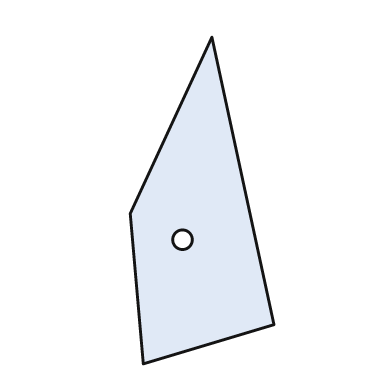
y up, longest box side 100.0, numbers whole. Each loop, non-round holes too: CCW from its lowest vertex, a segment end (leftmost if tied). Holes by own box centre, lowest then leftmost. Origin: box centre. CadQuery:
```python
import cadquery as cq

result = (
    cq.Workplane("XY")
    .moveTo(-18.0, -50.0)
    .lineTo(22.0, -38.0)
    .lineTo(3.0, 50.0)
    .lineTo(-22.0, -4.0)
    .close()
    .moveTo(-6.0, -12.0)
    .circle(3.0)
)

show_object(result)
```